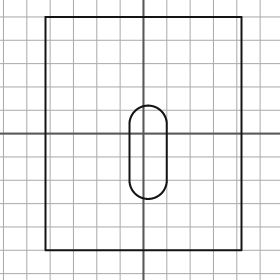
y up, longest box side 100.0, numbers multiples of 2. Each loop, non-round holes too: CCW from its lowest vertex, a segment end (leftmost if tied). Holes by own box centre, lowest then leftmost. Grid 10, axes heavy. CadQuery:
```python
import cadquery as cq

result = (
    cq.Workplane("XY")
    .moveTo(-42.0, -50.0)
    .lineTo(42.0, -50.0)
    .lineTo(42.0, 50.0)
    .lineTo(-42.0, 50.0)
    .close()
    .moveTo(-6.0, -20.0)
    .threePointArc((2.0, -28.0), (10.0, -20.0))
    .lineTo(10.0, 4.0)
    .threePointArc((2.0, 12.0), (-6.0, 4.0))
    .close()
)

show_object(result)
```